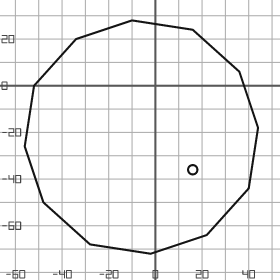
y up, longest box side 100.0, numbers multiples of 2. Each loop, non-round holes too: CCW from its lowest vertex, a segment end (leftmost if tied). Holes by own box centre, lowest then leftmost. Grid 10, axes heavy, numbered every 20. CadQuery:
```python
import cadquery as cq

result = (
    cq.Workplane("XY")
    .moveTo(-2.0, -72.0)
    .lineTo(22.0, -64.0)
    .lineTo(40.0, -44.0)
    .lineTo(44.0, -18.0)
    .lineTo(36.0, 6.0)
    .lineTo(16.0, 24.0)
    .lineTo(-10.0, 28.0)
    .lineTo(-34.0, 20.0)
    .lineTo(-52.0, 0.0)
    .lineTo(-56.0, -26.0)
    .lineTo(-48.0, -50.0)
    .lineTo(-28.0, -68.0)
    .close()
    .moveTo(16.0, -36.0)
    .circle(2.0)
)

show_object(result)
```